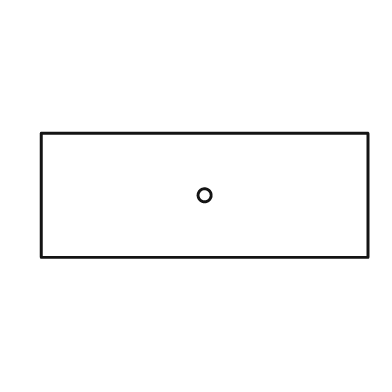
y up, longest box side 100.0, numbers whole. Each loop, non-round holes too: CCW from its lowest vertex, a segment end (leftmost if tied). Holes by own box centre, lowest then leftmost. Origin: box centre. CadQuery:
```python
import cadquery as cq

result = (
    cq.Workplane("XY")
    .moveTo(-50.0, -19.0)
    .lineTo(50.0, -19.0)
    .lineTo(50.0, 19.0)
    .lineTo(-50.0, 19.0)
    .close()
    .moveTo(0.0, 0.0)
    .circle(2.0)
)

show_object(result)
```